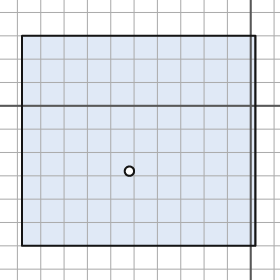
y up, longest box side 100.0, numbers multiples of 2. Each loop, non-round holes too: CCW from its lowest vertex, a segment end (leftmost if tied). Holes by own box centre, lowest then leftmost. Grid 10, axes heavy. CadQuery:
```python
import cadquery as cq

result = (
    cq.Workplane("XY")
    .moveTo(-98.0, -60.0)
    .lineTo(2.0, -60.0)
    .lineTo(2.0, 30.0)
    .lineTo(-98.0, 30.0)
    .close()
    .moveTo(-52.0, -28.0)
    .circle(2.0)
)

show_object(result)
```